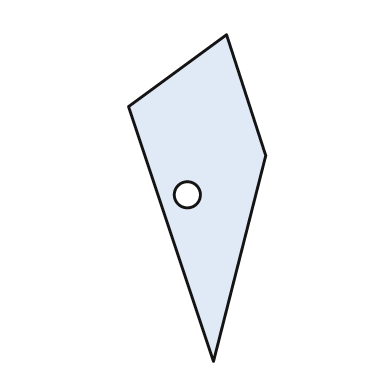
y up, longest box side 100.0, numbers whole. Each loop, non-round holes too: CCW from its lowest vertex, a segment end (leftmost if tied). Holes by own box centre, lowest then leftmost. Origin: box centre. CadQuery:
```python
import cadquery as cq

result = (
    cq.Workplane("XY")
    .moveTo(5.0, -50.0)
    .lineTo(21.0, 13.0)
    .lineTo(9.0, 50.0)
    .lineTo(-21.0, 28.0)
    .close()
    .moveTo(-3.0, 1.0)
    .circle(4.0)
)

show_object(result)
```